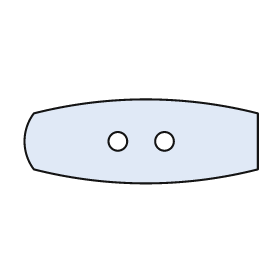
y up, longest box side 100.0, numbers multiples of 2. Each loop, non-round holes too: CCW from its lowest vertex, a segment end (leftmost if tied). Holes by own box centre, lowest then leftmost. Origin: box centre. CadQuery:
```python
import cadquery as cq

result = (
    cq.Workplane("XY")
    .moveTo(-46.0, -12.0)
    .threePointArc((2.0, -18.0), (50.0, -12.0))
    .lineTo(50.0, 12.0)
    .threePointArc((2.0, 18.0), (-46.0, 12.0))
    .threePointArc((-50.0, 0.0), (-46.0, -12.0))
    .close()
    .moveTo(-10.0, 0.0)
    .circle(4.0)
    .moveTo(10.0, 0.0)
    .circle(4.0)
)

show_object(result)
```